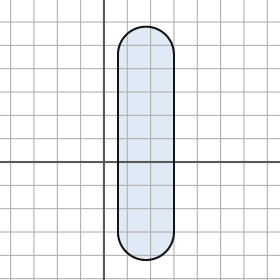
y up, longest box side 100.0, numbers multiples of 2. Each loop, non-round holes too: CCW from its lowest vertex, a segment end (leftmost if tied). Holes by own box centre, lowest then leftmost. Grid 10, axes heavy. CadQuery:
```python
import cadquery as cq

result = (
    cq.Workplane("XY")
    .moveTo(6.0, -30.0)
    .threePointArc((18.0, -42.0), (30.0, -30.0))
    .lineTo(30.0, 46.0)
    .threePointArc((18.0, 58.0), (6.0, 46.0))
    .close()
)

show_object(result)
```